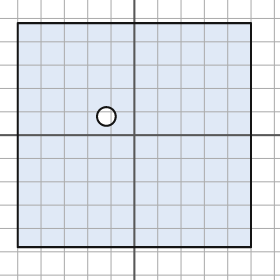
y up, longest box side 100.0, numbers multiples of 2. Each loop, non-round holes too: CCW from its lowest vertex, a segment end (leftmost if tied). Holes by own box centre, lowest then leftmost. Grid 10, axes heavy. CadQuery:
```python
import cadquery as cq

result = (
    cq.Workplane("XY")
    .moveTo(-50.0, -48.0)
    .lineTo(50.0, -48.0)
    .lineTo(50.0, 48.0)
    .lineTo(-50.0, 48.0)
    .close()
    .moveTo(-12.0, 8.0)
    .circle(4.0)
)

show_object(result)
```